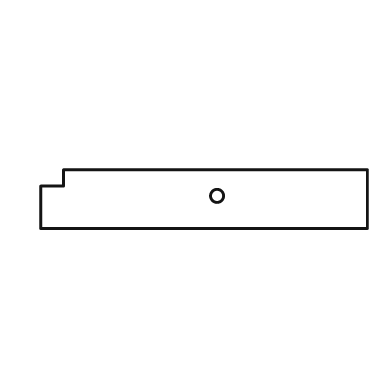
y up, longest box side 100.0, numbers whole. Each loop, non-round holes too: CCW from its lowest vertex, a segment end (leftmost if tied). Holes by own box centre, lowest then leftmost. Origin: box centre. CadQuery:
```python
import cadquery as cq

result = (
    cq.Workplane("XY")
    .moveTo(-50.0, -9.0)
    .lineTo(50.0, -9.0)
    .lineTo(50.0, 9.0)
    .lineTo(-43.0, 9.0)
    .lineTo(-43.0, 4.0)
    .lineTo(-50.0, 4.0)
    .close()
    .moveTo(4.0, 1.0)
    .circle(2.0)
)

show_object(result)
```